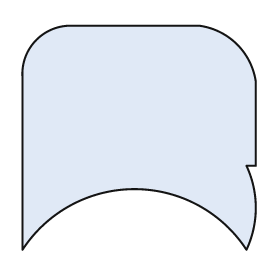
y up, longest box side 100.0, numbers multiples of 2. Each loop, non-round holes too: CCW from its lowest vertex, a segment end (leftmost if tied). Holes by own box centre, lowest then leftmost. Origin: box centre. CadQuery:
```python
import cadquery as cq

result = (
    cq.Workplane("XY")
    .moveTo(-50.0, -48.0)
    .threePointArc((-2.0, -22.0), (46.0, -48.0))
    .threePointArc((50.0, -30.0), (46.0, -12.0))
    .lineTo(50.0, -12.0)
    .lineTo(50.0, 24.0)
    .threePointArc((42.0, 40.0), (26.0, 48.0))
    .lineTo(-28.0, 48.0)
    .threePointArc((-44.0, 42.0), (-50.0, 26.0))
    .close()
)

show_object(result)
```